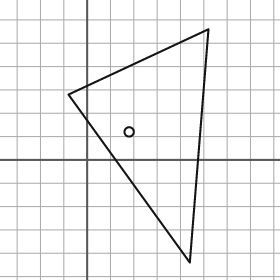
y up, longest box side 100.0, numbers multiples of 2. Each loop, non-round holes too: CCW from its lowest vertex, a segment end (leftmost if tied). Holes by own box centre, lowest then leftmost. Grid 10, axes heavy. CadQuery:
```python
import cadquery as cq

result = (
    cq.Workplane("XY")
    .moveTo(44.0, -44.0)
    .lineTo(52.0, 56.0)
    .lineTo(-8.0, 28.0)
    .close()
    .moveTo(18.0, 12.0)
    .circle(2.0)
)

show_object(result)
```